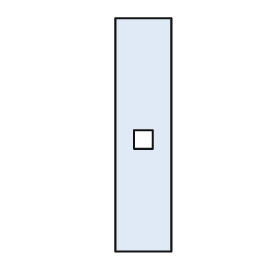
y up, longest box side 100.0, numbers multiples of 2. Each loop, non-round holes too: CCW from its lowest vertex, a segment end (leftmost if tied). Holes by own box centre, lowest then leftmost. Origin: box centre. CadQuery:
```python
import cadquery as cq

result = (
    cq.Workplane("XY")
    .moveTo(-12.0, -50.0)
    .lineTo(12.0, -50.0)
    .lineTo(12.0, 50.0)
    .lineTo(-12.0, 50.0)
    .close()
    .moveTo(-4.0, -6.0)
    .lineTo(4.0, -6.0)
    .lineTo(4.0, 2.0)
    .lineTo(-4.0, 2.0)
    .close()
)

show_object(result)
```